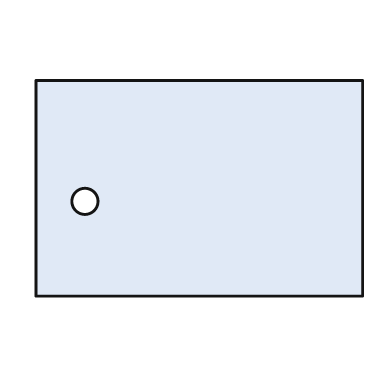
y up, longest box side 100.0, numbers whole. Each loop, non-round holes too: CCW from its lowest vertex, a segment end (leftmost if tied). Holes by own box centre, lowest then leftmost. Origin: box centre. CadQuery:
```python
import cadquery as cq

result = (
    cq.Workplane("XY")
    .moveTo(-50.0, -33.0)
    .lineTo(50.0, -33.0)
    .lineTo(50.0, 33.0)
    .lineTo(-50.0, 33.0)
    .close()
    .moveTo(-35.0, -4.0)
    .circle(4.0)
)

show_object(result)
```